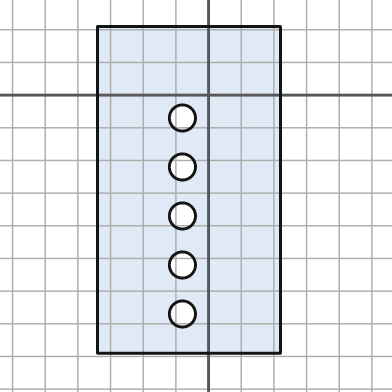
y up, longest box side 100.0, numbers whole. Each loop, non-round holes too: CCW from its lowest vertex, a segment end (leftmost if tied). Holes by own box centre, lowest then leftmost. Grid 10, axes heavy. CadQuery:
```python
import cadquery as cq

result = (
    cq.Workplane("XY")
    .moveTo(-34.0, -79.0)
    .lineTo(22.0, -79.0)
    .lineTo(22.0, 21.0)
    .lineTo(-34.0, 21.0)
    .close()
    .moveTo(-8.0, -67.0)
    .circle(4.0)
    .moveTo(-8.0, -52.0)
    .circle(4.0)
    .moveTo(-8.0, -37.0)
    .circle(4.0)
    .moveTo(-8.0, -22.0)
    .circle(4.0)
    .moveTo(-8.0, -7.0)
    .circle(4.0)
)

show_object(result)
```